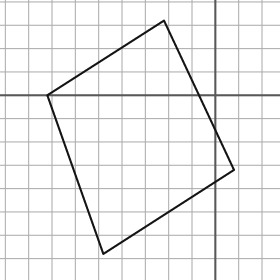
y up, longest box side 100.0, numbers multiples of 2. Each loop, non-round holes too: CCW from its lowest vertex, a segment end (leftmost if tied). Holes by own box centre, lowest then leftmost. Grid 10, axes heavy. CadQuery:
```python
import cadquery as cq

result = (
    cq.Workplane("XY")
    .moveTo(-48.0, -68.0)
    .lineTo(8.0, -32.0)
    .lineTo(-22.0, 32.0)
    .lineTo(-72.0, 0.0)
    .close()
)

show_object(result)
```